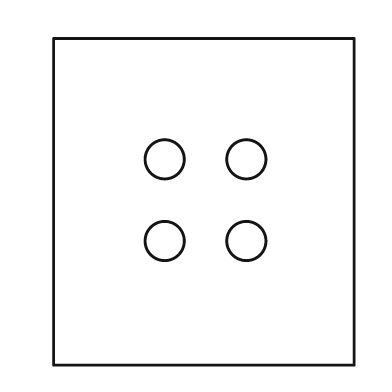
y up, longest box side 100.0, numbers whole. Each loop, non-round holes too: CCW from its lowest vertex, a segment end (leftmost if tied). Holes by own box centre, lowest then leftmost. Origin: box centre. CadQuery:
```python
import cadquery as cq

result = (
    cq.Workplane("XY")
    .moveTo(-46.0, -50.0)
    .lineTo(46.0, -50.0)
    .lineTo(46.0, 50.0)
    .lineTo(-46.0, 50.0)
    .close()
    .moveTo(-12.0, -12.0)
    .circle(6.0)
    .moveTo(13.0, -12.0)
    .circle(6.0)
    .moveTo(-12.0, 13.0)
    .circle(6.0)
    .moveTo(13.0, 13.0)
    .circle(6.0)
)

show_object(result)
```